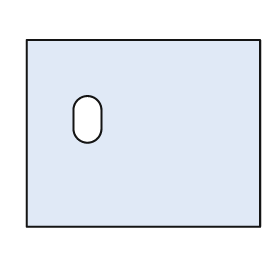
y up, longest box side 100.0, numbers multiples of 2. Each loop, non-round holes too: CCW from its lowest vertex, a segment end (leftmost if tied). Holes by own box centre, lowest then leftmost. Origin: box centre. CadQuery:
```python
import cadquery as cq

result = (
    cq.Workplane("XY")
    .moveTo(-50.0, -40.0)
    .lineTo(50.0, -40.0)
    .lineTo(50.0, 40.0)
    .lineTo(-50.0, 40.0)
    .close()
    .moveTo(-30.0, 2.0)
    .threePointArc((-24.0, -4.0), (-18.0, 2.0))
    .lineTo(-18.0, 10.0)
    .threePointArc((-24.0, 16.0), (-30.0, 10.0))
    .close()
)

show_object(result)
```